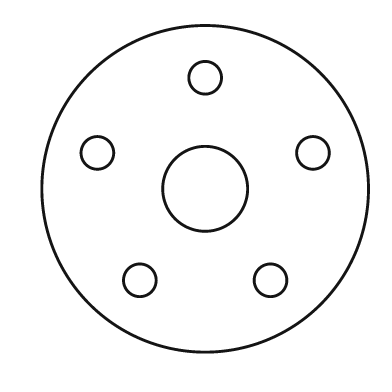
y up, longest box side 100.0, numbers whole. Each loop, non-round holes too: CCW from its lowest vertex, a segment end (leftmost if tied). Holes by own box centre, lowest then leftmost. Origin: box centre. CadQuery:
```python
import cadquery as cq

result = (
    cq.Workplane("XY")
    .moveTo(0.0, 0.0)
    .circle(50.0)
    .moveTo(-20.0, -28.0)
    .circle(5.0)
    .moveTo(20.0, -28.0)
    .circle(5.0)
    .moveTo(0.0, 0.0)
    .circle(13.0)
    .moveTo(-33.0, 11.0)
    .circle(5.0)
    .moveTo(33.0, 11.0)
    .circle(5.0)
    .moveTo(0.0, 34.0)
    .circle(5.0)
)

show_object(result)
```